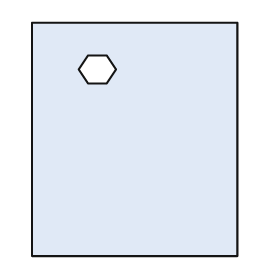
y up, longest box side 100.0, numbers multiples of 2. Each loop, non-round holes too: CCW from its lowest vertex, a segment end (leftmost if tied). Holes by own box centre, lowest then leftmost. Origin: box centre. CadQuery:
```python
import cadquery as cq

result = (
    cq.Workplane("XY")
    .moveTo(-44.0, -50.0)
    .lineTo(44.0, -50.0)
    .lineTo(44.0, 50.0)
    .lineTo(-44.0, 50.0)
    .close()
    .moveTo(-20.0, 24.0)
    .lineTo(-12.0, 24.0)
    .lineTo(-8.0, 30.0)
    .lineTo(-12.0, 36.0)
    .lineTo(-20.0, 36.0)
    .lineTo(-24.0, 30.0)
    .close()
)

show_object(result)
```